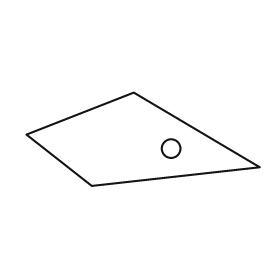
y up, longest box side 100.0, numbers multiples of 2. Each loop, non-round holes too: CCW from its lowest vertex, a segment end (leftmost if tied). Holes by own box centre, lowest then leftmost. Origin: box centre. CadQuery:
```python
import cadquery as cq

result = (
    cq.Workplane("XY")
    .moveTo(-22.0, -20.0)
    .lineTo(50.0, -12.0)
    .lineTo(-4.0, 20.0)
    .lineTo(-50.0, 2.0)
    .close()
    .moveTo(12.0, -4.0)
    .circle(4.0)
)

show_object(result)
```